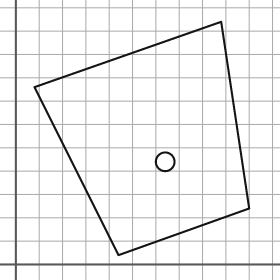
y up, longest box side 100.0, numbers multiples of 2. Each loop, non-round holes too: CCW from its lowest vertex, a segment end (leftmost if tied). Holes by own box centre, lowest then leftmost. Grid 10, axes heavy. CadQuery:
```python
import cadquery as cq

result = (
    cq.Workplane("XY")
    .moveTo(44.0, 4.0)
    .lineTo(100.0, 24.0)
    .lineTo(88.0, 104.0)
    .lineTo(8.0, 76.0)
    .close()
    .moveTo(64.0, 44.0)
    .circle(4.0)
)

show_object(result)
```